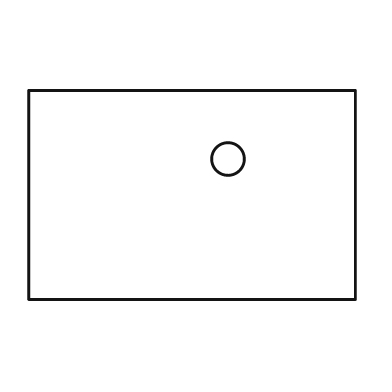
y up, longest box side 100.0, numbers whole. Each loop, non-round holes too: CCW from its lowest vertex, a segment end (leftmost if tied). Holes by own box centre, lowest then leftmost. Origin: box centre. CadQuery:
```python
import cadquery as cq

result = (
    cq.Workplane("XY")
    .moveTo(-50.0, -32.0)
    .lineTo(50.0, -32.0)
    .lineTo(50.0, 32.0)
    .lineTo(-50.0, 32.0)
    .close()
    .moveTo(11.0, 11.0)
    .circle(5.0)
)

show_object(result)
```